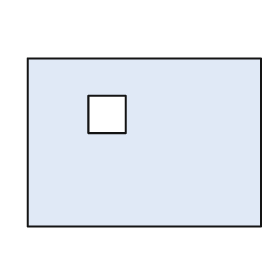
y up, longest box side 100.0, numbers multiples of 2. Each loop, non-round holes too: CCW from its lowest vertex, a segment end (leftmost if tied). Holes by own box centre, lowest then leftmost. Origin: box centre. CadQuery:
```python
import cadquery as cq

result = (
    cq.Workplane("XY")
    .moveTo(-50.0, -36.0)
    .lineTo(50.0, -36.0)
    .lineTo(50.0, 36.0)
    .lineTo(-50.0, 36.0)
    .close()
    .moveTo(-24.0, 4.0)
    .lineTo(-8.0, 4.0)
    .lineTo(-8.0, 20.0)
    .lineTo(-24.0, 20.0)
    .close()
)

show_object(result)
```